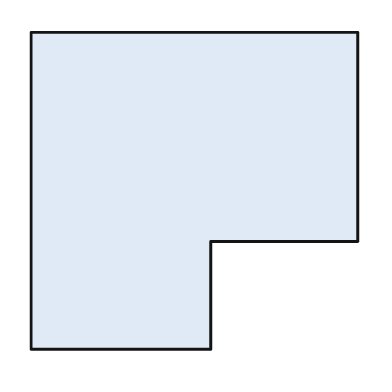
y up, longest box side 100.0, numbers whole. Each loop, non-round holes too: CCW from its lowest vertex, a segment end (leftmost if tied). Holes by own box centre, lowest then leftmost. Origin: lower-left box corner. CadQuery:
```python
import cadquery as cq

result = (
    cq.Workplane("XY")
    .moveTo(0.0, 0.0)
    .lineTo(55.0, 0.0)
    .lineTo(55.0, 33.0)
    .lineTo(100.0, 33.0)
    .lineTo(100.0, 97.0)
    .lineTo(0.0, 97.0)
    .close()
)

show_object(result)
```